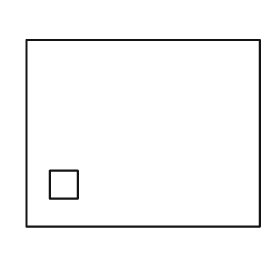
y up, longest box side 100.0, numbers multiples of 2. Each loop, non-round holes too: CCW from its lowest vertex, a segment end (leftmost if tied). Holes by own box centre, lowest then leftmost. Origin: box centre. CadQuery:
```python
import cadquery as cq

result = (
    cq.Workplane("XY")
    .moveTo(-50.0, -40.0)
    .lineTo(50.0, -40.0)
    .lineTo(50.0, 40.0)
    .lineTo(-50.0, 40.0)
    .close()
    .moveTo(-40.0, -28.0)
    .lineTo(-28.0, -28.0)
    .lineTo(-28.0, -16.0)
    .lineTo(-40.0, -16.0)
    .close()
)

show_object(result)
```